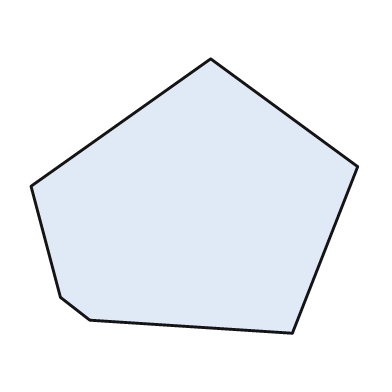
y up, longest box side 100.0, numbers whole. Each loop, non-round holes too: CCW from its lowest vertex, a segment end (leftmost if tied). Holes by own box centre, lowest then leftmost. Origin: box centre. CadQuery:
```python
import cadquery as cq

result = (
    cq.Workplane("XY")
    .moveTo(30.0, -42.0)
    .lineTo(50.0, 9.0)
    .lineTo(5.0, 42.0)
    .lineTo(-50.0, 3.0)
    .lineTo(-41.0, -31.0)
    .lineTo(-32.0, -38.0)
    .close()
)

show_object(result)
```